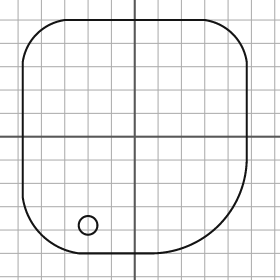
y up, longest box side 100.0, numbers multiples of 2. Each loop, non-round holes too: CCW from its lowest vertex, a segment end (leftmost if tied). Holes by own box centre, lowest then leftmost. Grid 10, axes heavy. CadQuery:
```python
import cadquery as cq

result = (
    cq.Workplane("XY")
    .moveTo(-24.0, -50.0)
    .lineTo(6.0, -50.0)
    .threePointArc((36.0, -38.0), (48.0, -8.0))
    .lineTo(48.0, 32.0)
    .threePointArc((42.0, 44.0), (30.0, 50.0))
    .lineTo(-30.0, 50.0)
    .threePointArc((-42.0, 44.0), (-48.0, 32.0))
    .lineTo(-48.0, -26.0)
    .threePointArc((-40.0, -42.0), (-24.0, -50.0))
    .close()
    .moveTo(-20.0, -38.0)
    .circle(4.0)
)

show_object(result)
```